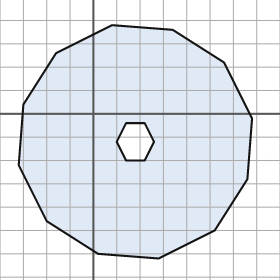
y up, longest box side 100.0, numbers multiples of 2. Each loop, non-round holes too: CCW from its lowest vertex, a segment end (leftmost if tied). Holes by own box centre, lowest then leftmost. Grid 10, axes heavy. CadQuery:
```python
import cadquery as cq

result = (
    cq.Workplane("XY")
    .moveTo(28.0, -62.0)
    .lineTo(52.0, -50.0)
    .lineTo(66.0, -28.0)
    .lineTo(68.0, -2.0)
    .lineTo(56.0, 22.0)
    .lineTo(34.0, 36.0)
    .lineTo(8.0, 38.0)
    .lineTo(-16.0, 26.0)
    .lineTo(-30.0, 4.0)
    .lineTo(-32.0, -22.0)
    .lineTo(-20.0, -46.0)
    .lineTo(2.0, -60.0)
    .close()
    .moveTo(14.0, -20.0)
    .lineTo(22.0, -20.0)
    .lineTo(26.0, -12.0)
    .lineTo(22.0, -4.0)
    .lineTo(14.0, -4.0)
    .lineTo(10.0, -12.0)
    .close()
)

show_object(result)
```